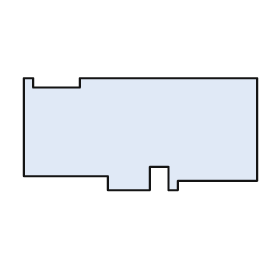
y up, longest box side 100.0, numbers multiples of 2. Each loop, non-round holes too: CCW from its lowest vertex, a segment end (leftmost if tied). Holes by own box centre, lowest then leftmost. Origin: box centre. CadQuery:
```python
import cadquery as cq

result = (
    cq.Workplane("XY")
    .moveTo(-14.0, -24.0)
    .lineTo(4.0, -24.0)
    .lineTo(4.0, -14.0)
    .lineTo(12.0, -14.0)
    .lineTo(12.0, -24.0)
    .lineTo(16.0, -24.0)
    .lineTo(16.0, -20.0)
    .lineTo(50.0, -20.0)
    .lineTo(50.0, 24.0)
    .lineTo(-26.0, 24.0)
    .lineTo(-26.0, 20.0)
    .lineTo(-46.0, 20.0)
    .lineTo(-46.0, 24.0)
    .lineTo(-50.0, 24.0)
    .lineTo(-50.0, -18.0)
    .lineTo(-14.0, -18.0)
    .close()
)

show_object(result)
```